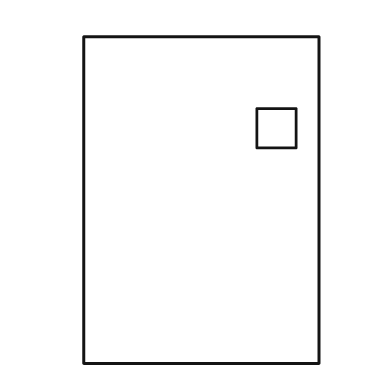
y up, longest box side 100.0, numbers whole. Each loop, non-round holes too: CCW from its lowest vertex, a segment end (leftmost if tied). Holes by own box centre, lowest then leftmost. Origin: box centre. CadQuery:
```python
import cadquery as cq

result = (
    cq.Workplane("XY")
    .moveTo(-36.0, -50.0)
    .lineTo(36.0, -50.0)
    .lineTo(36.0, 50.0)
    .lineTo(-36.0, 50.0)
    .close()
    .moveTo(17.0, 16.0)
    .lineTo(29.0, 16.0)
    .lineTo(29.0, 28.0)
    .lineTo(17.0, 28.0)
    .close()
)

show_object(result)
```